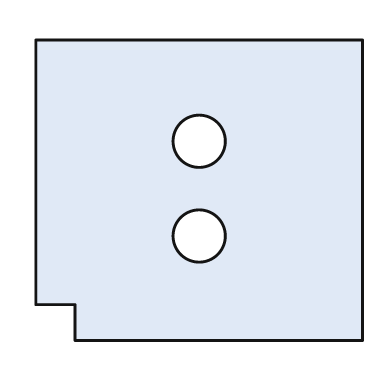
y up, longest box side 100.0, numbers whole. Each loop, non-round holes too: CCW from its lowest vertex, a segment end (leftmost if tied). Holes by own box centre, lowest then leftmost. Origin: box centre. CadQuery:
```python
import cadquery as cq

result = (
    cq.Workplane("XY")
    .moveTo(-38.0, -46.0)
    .lineTo(50.0, -46.0)
    .lineTo(50.0, 46.0)
    .lineTo(-50.0, 46.0)
    .lineTo(-50.0, -35.0)
    .lineTo(-38.0, -35.0)
    .close()
    .moveTo(0.0, -14.0)
    .circle(8.0)
    .moveTo(0.0, 15.0)
    .circle(8.0)
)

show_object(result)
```